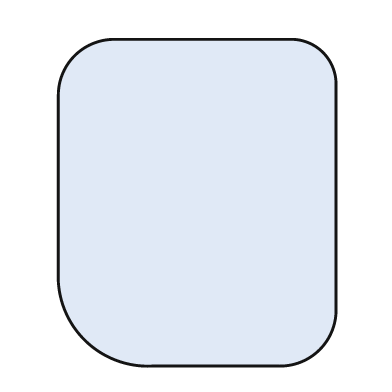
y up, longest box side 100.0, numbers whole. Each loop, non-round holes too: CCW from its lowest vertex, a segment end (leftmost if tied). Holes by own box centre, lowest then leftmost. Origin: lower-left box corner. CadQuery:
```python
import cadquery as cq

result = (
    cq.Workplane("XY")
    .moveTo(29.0, 0.0)
    .lineTo(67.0, 0.0)
    .threePointArc((80.0, 5.0), (85.0, 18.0))
    .lineTo(85.0, 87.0)
    .threePointArc((81.0, 96.0), (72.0, 100.0))
    .lineTo(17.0, 100.0)
    .threePointArc((5.0, 95.0), (0.0, 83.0))
    .lineTo(0.0, 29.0)
    .threePointArc((8.0, 8.0), (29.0, 0.0))
    .close()
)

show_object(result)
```